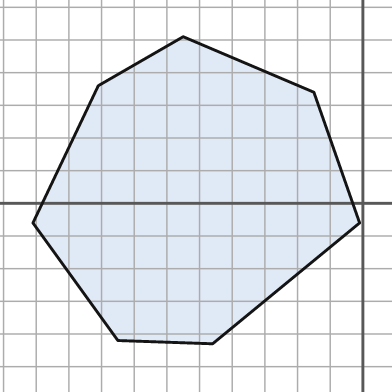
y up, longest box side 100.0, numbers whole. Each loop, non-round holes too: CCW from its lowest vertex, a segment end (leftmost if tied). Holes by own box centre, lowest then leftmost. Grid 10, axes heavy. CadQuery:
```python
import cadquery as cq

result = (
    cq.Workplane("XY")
    .moveTo(-46.0, -43.0)
    .lineTo(-1.0, -6.0)
    .lineTo(-15.0, 34.0)
    .lineTo(-55.0, 51.0)
    .lineTo(-81.0, 36.0)
    .lineTo(-101.0, -6.0)
    .lineTo(-75.0, -42.0)
    .close()
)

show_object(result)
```